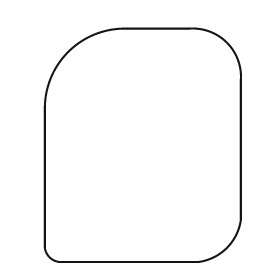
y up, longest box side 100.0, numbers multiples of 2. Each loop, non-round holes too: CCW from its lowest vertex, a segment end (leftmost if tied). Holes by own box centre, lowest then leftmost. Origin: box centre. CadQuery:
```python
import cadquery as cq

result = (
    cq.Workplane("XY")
    .moveTo(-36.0, -50.0)
    .lineTo(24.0, -50.0)
    .threePointArc((36.0, -44.0), (42.0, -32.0))
    .lineTo(42.0, 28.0)
    .threePointArc((36.0, 44.0), (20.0, 50.0))
    .lineTo(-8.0, 50.0)
    .threePointArc((-32.0, 40.0), (-42.0, 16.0))
    .lineTo(-42.0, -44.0)
    .threePointArc((-40.0, -48.0), (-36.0, -50.0))
    .close()
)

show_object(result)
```